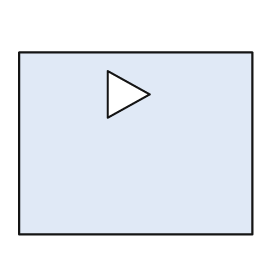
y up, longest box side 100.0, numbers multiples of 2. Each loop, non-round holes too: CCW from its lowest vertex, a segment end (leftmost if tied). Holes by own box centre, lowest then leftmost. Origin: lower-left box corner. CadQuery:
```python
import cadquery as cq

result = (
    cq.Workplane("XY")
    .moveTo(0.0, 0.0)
    .lineTo(100.0, 0.0)
    .lineTo(100.0, 78.0)
    .lineTo(0.0, 78.0)
    .close()
    .moveTo(38.0, 50.0)
    .lineTo(56.0, 60.0)
    .lineTo(38.0, 70.0)
    .close()
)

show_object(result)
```